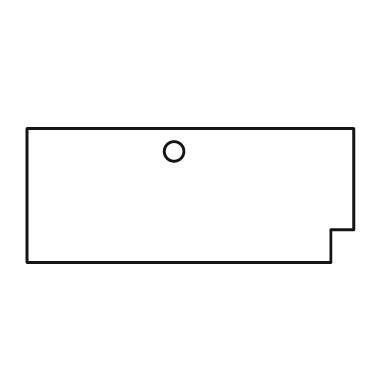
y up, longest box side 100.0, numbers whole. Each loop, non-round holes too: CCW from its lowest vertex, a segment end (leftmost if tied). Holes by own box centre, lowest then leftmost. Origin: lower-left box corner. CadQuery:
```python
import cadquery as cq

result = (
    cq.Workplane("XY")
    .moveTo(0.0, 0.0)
    .lineTo(93.0, 0.0)
    .lineTo(93.0, 10.0)
    .lineTo(100.0, 10.0)
    .lineTo(100.0, 41.0)
    .lineTo(0.0, 41.0)
    .close()
    .moveTo(45.0, 34.0)
    .circle(3.0)
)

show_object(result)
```